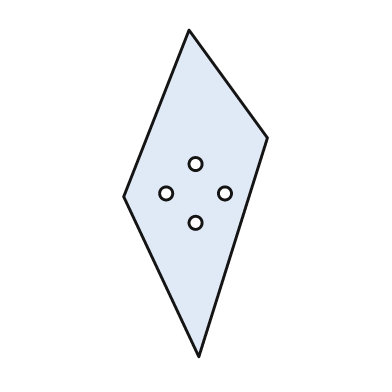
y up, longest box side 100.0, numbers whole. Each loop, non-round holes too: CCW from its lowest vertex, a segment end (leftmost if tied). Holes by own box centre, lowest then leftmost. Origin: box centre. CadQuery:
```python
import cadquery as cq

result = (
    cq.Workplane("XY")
    .moveTo(1.0, -50.0)
    .lineTo(22.0, 17.0)
    .lineTo(-2.0, 50.0)
    .lineTo(-22.0, -1.0)
    .close()
    .moveTo(0.0, -9.0)
    .circle(2.0)
    .moveTo(-9.0, 0.0)
    .circle(2.0)
    .moveTo(9.0, 0.0)
    .circle(2.0)
    .moveTo(0.0, 9.0)
    .circle(2.0)
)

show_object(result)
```